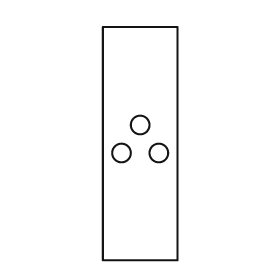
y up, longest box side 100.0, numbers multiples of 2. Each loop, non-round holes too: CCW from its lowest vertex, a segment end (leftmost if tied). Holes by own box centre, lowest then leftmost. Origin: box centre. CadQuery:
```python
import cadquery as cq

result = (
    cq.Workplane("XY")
    .moveTo(-16.0, -50.0)
    .lineTo(16.0, -50.0)
    .lineTo(16.0, 50.0)
    .lineTo(-16.0, 50.0)
    .close()
    .moveTo(-8.0, -4.0)
    .circle(4.0)
    .moveTo(8.0, -4.0)
    .circle(4.0)
    .moveTo(0.0, 8.0)
    .circle(4.0)
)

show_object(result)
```